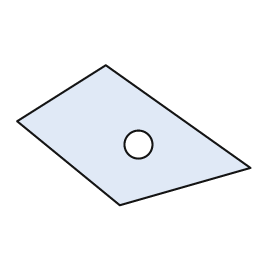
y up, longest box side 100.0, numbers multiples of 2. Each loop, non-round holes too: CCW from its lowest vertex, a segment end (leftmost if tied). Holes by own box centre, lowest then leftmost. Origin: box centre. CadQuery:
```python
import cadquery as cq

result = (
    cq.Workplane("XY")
    .moveTo(-6.0, -30.0)
    .lineTo(50.0, -14.0)
    .lineTo(-12.0, 30.0)
    .lineTo(-50.0, 6.0)
    .close()
    .moveTo(2.0, -4.0)
    .circle(6.0)
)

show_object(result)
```